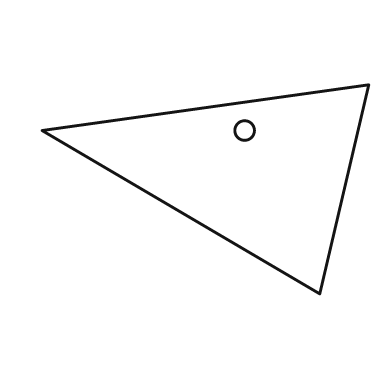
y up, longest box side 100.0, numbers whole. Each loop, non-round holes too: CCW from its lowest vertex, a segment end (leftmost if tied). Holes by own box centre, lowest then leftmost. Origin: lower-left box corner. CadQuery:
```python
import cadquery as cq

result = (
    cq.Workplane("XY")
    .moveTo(85.0, 0.0)
    .lineTo(100.0, 64.0)
    .lineTo(0.0, 50.0)
    .close()
    .moveTo(62.0, 50.0)
    .circle(3.0)
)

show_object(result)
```